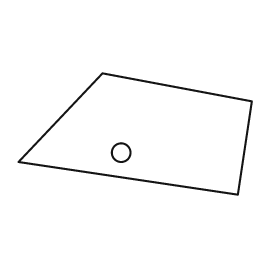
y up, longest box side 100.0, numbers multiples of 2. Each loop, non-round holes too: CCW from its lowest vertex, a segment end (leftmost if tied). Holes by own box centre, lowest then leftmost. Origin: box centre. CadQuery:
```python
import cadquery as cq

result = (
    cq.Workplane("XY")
    .moveTo(44.0, -26.0)
    .lineTo(50.0, 14.0)
    .lineTo(-14.0, 26.0)
    .lineTo(-50.0, -12.0)
    .close()
    .moveTo(-6.0, -8.0)
    .circle(4.0)
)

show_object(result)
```